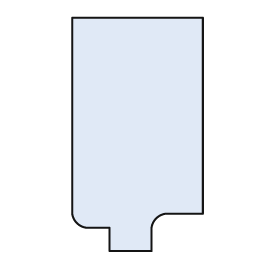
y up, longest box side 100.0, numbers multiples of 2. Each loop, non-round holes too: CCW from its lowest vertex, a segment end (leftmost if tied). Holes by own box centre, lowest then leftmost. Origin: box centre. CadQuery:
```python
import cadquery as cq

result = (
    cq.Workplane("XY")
    .moveTo(-12.0, -50.0)
    .lineTo(6.0, -50.0)
    .lineTo(6.0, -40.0)
    .threePointArc((8.0, -36.0), (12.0, -34.0))
    .lineTo(28.0, -34.0)
    .lineTo(28.0, 50.0)
    .lineTo(-28.0, 50.0)
    .lineTo(-28.0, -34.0)
    .threePointArc((-26.0, -38.0), (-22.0, -40.0))
    .lineTo(-12.0, -40.0)
    .close()
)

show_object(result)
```